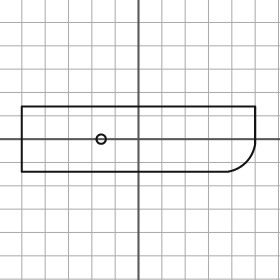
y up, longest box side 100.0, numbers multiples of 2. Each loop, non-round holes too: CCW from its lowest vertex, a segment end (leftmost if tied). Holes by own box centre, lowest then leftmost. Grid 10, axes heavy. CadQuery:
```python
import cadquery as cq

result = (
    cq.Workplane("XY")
    .moveTo(-50.0, -14.0)
    .lineTo(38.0, -14.0)
    .threePointArc((46.0, -10.0), (50.0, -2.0))
    .lineTo(50.0, 14.0)
    .lineTo(-50.0, 14.0)
    .close()
    .moveTo(-16.0, 0.0)
    .circle(2.0)
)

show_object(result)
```